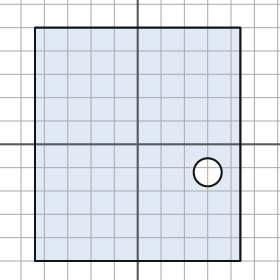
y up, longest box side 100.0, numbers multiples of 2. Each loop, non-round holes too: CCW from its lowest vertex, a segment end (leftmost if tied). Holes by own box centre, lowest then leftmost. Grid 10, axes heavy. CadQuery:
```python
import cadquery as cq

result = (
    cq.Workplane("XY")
    .moveTo(-44.0, -50.0)
    .lineTo(44.0, -50.0)
    .lineTo(44.0, 50.0)
    .lineTo(-44.0, 50.0)
    .close()
    .moveTo(30.0, -12.0)
    .circle(6.0)
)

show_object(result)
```